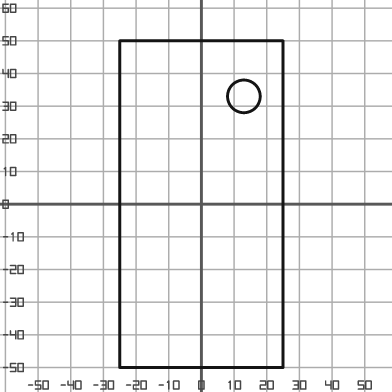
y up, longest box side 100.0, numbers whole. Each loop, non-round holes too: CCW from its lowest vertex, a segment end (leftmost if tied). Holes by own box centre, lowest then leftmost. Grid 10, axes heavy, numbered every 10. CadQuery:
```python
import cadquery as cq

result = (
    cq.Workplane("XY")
    .moveTo(-25.0, -50.0)
    .lineTo(25.0, -50.0)
    .lineTo(25.0, 50.0)
    .lineTo(-25.0, 50.0)
    .close()
    .moveTo(13.0, 33.0)
    .circle(5.0)
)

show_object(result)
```